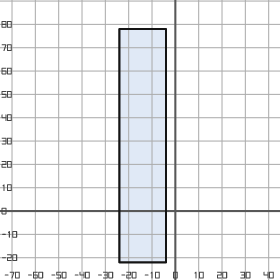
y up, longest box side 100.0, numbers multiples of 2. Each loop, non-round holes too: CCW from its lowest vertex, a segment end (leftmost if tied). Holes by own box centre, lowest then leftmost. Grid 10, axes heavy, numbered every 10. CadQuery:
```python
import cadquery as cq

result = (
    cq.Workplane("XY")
    .moveTo(-24.0, -22.0)
    .lineTo(-4.0, -22.0)
    .lineTo(-4.0, 78.0)
    .lineTo(-24.0, 78.0)
    .close()
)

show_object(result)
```